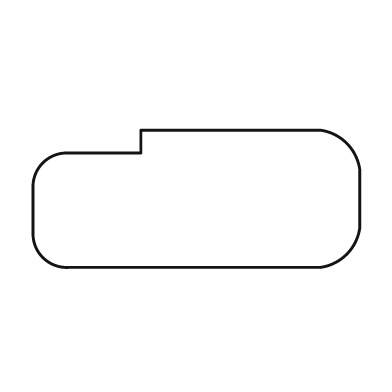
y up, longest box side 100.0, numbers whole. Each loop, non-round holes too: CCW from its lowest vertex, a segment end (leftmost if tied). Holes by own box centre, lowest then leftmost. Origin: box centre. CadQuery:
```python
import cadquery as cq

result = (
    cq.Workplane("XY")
    .moveTo(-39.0, -21.0)
    .lineTo(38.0, -21.0)
    .threePointArc((46.0, -17.0), (50.0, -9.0))
    .lineTo(50.0, 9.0)
    .threePointArc((46.0, 17.0), (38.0, 21.0))
    .lineTo(-17.0, 21.0)
    .lineTo(-17.0, 14.0)
    .lineTo(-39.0, 14.0)
    .threePointArc((-47.0, 11.0), (-50.0, 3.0))
    .lineTo(-50.0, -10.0)
    .threePointArc((-47.0, -18.0), (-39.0, -21.0))
    .close()
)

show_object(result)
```